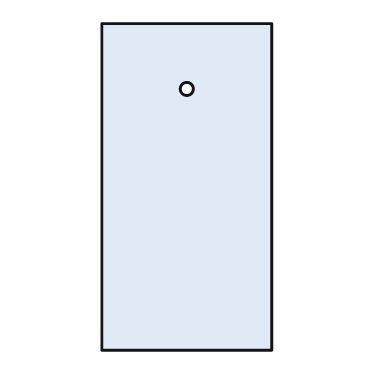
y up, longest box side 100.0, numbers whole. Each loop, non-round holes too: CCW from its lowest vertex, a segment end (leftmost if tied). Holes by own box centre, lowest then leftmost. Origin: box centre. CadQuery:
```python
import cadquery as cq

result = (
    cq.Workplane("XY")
    .moveTo(-26.0, -50.0)
    .lineTo(26.0, -50.0)
    .lineTo(26.0, 50.0)
    .lineTo(-26.0, 50.0)
    .close()
    .moveTo(0.0, 30.0)
    .circle(2.0)
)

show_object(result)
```